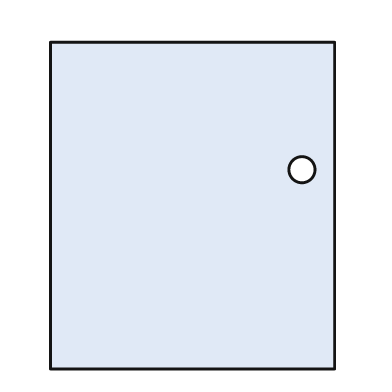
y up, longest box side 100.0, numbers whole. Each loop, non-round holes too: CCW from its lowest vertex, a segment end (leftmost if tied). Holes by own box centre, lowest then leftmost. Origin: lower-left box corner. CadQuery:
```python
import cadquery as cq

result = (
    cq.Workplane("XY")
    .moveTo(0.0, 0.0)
    .lineTo(87.0, 0.0)
    .lineTo(87.0, 100.0)
    .lineTo(0.0, 100.0)
    .close()
    .moveTo(77.0, 61.0)
    .circle(4.0)
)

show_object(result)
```